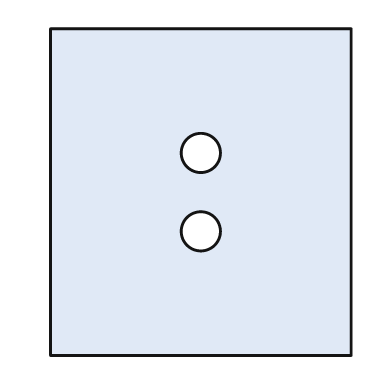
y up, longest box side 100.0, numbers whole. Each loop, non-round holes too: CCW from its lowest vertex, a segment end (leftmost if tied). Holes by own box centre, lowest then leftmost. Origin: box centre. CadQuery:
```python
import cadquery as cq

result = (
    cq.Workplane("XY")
    .moveTo(-46.0, -50.0)
    .lineTo(46.0, -50.0)
    .lineTo(46.0, 50.0)
    .lineTo(-46.0, 50.0)
    .close()
    .moveTo(0.0, -12.0)
    .circle(6.0)
    .moveTo(0.0, 12.0)
    .circle(6.0)
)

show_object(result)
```